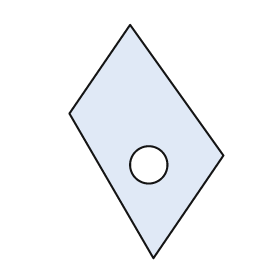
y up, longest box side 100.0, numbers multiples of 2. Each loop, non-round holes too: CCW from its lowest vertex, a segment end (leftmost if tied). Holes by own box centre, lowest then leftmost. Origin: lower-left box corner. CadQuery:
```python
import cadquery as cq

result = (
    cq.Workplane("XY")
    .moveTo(36.0, 0.0)
    .lineTo(66.0, 44.0)
    .lineTo(26.0, 100.0)
    .lineTo(0.0, 62.0)
    .close()
    .moveTo(34.0, 40.0)
    .circle(8.0)
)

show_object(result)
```